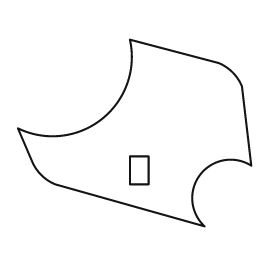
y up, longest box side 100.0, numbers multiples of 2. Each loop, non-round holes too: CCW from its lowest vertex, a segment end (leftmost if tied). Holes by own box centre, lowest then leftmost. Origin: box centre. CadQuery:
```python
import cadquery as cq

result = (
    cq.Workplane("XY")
    .moveTo(30.0, -40.0)
    .threePointArc((28.0, -18.0), (50.0, -14.0))
    .lineTo(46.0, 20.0)
    .threePointArc((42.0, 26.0), (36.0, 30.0))
    .lineTo(-2.0, 40.0)
    .threePointArc((-14.0, 6.0), (-50.0, 2.0))
    .lineTo(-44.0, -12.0)
    .threePointArc((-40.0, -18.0), (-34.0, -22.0))
    .close()
    .moveTo(-2.0, -22.0)
    .lineTo(6.0, -22.0)
    .lineTo(6.0, -10.0)
    .lineTo(-2.0, -10.0)
    .close()
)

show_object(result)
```